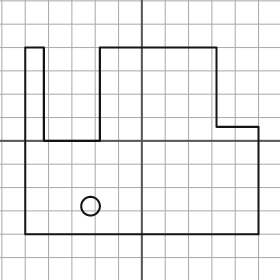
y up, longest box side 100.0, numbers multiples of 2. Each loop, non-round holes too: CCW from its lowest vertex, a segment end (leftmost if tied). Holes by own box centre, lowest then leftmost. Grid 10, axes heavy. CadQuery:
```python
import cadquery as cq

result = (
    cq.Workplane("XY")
    .moveTo(-50.0, -40.0)
    .lineTo(50.0, -40.0)
    .lineTo(50.0, 6.0)
    .lineTo(32.0, 6.0)
    .lineTo(32.0, 40.0)
    .lineTo(-18.0, 40.0)
    .lineTo(-18.0, 0.0)
    .lineTo(-42.0, 0.0)
    .lineTo(-42.0, 40.0)
    .lineTo(-50.0, 40.0)
    .close()
    .moveTo(-22.0, -28.0)
    .circle(4.0)
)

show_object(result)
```